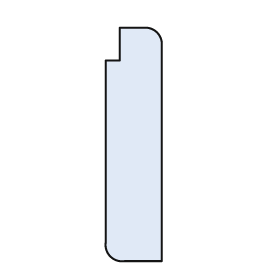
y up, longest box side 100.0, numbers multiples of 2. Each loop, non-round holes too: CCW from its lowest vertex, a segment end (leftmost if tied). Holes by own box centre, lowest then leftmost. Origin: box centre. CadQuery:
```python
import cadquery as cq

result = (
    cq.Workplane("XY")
    .moveTo(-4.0, -50.0)
    .lineTo(12.0, -50.0)
    .lineTo(12.0, 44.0)
    .threePointArc((10.0, 48.0), (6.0, 50.0))
    .lineTo(-6.0, 50.0)
    .lineTo(-6.0, 36.0)
    .lineTo(-12.0, 36.0)
    .lineTo(-12.0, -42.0)
    .threePointArc((-10.0, -48.0), (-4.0, -50.0))
    .close()
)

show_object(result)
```